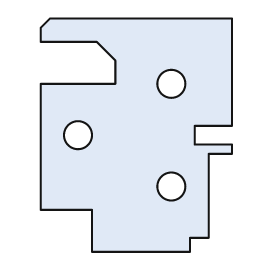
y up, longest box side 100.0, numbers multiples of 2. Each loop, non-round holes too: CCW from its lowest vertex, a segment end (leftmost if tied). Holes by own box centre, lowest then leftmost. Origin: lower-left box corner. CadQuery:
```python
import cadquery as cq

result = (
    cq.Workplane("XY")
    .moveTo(22.0, 0.0)
    .lineTo(64.0, 0.0)
    .lineTo(64.0, 6.0)
    .lineTo(72.0, 6.0)
    .lineTo(72.0, 42.0)
    .lineTo(82.0, 42.0)
    .lineTo(82.0, 46.0)
    .lineTo(66.0, 46.0)
    .lineTo(66.0, 54.0)
    .lineTo(82.0, 54.0)
    .lineTo(82.0, 100.0)
    .lineTo(4.0, 100.0)
    .lineTo(0.0, 96.0)
    .lineTo(0.0, 90.0)
    .lineTo(24.0, 90.0)
    .lineTo(32.0, 82.0)
    .lineTo(32.0, 72.0)
    .lineTo(0.0, 72.0)
    .lineTo(0.0, 18.0)
    .lineTo(22.0, 18.0)
    .close()
    .moveTo(56.0, 28.0)
    .circle(6.0)
    .moveTo(16.0, 50.0)
    .circle(6.0)
    .moveTo(56.0, 72.0)
    .circle(6.0)
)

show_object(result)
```